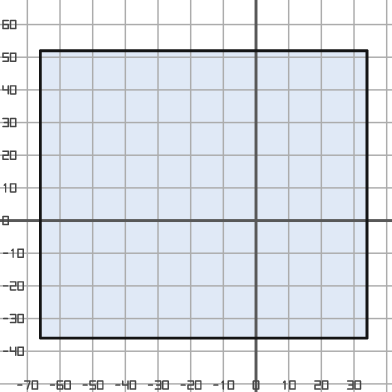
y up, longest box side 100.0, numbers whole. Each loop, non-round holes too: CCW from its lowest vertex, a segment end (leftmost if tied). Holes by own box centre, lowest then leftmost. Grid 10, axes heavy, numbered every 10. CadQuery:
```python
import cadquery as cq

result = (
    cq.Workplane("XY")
    .moveTo(-66.0, -36.0)
    .lineTo(34.0, -36.0)
    .lineTo(34.0, 52.0)
    .lineTo(-66.0, 52.0)
    .close()
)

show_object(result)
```